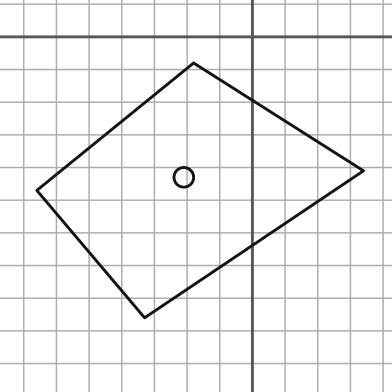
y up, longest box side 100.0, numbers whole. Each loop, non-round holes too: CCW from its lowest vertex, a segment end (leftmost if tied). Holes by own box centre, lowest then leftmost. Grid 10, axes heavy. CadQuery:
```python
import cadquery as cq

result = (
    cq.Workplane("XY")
    .moveTo(-33.0, -86.0)
    .lineTo(34.0, -41.0)
    .lineTo(-18.0, -8.0)
    .lineTo(-66.0, -47.0)
    .close()
    .moveTo(-21.0, -43.0)
    .circle(3.0)
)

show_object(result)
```